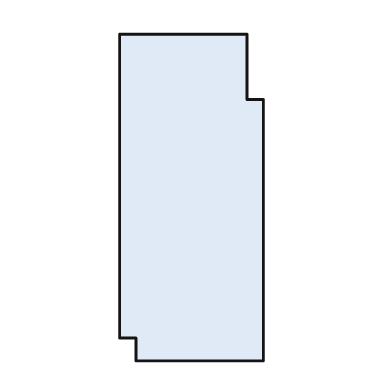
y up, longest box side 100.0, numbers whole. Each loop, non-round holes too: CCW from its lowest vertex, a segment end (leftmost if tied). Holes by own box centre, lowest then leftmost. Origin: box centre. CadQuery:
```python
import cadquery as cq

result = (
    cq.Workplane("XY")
    .moveTo(-17.0, -50.0)
    .lineTo(22.0, -50.0)
    .lineTo(22.0, 30.0)
    .lineTo(17.0, 30.0)
    .lineTo(17.0, 50.0)
    .lineTo(-22.0, 50.0)
    .lineTo(-22.0, -43.0)
    .lineTo(-17.0, -43.0)
    .close()
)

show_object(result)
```